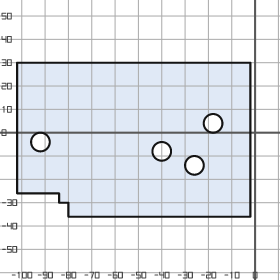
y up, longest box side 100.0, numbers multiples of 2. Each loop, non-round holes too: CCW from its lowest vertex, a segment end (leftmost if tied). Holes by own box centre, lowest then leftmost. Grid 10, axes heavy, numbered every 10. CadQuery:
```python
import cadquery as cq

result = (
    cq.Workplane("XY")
    .moveTo(-80.0, -36.0)
    .lineTo(-2.0, -36.0)
    .lineTo(-2.0, 30.0)
    .lineTo(-102.0, 30.0)
    .lineTo(-102.0, -26.0)
    .lineTo(-84.0, -26.0)
    .lineTo(-84.0, -30.0)
    .lineTo(-80.0, -30.0)
    .close()
    .moveTo(-26.0, -14.0)
    .circle(4.0)
    .moveTo(-40.0, -8.0)
    .circle(4.0)
    .moveTo(-92.0, -4.0)
    .circle(4.0)
    .moveTo(-18.0, 4.0)
    .circle(4.0)
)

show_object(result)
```